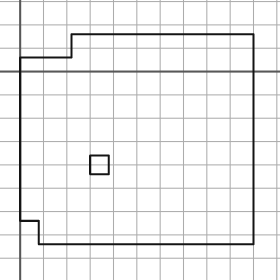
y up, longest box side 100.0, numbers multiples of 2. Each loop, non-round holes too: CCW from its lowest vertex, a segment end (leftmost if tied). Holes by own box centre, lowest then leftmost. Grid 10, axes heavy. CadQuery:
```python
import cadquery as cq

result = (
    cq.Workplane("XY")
    .moveTo(8.0, -74.0)
    .lineTo(100.0, -74.0)
    .lineTo(100.0, 16.0)
    .lineTo(22.0, 16.0)
    .lineTo(22.0, 6.0)
    .lineTo(0.0, 6.0)
    .lineTo(0.0, -64.0)
    .lineTo(8.0, -64.0)
    .close()
    .moveTo(30.0, -44.0)
    .lineTo(38.0, -44.0)
    .lineTo(38.0, -36.0)
    .lineTo(30.0, -36.0)
    .close()
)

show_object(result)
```